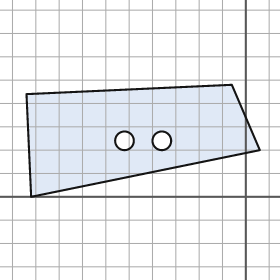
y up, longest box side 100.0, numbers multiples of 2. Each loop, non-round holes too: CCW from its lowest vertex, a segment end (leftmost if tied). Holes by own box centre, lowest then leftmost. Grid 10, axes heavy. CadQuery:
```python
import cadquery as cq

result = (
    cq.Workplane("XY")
    .moveTo(-92.0, 0.0)
    .lineTo(6.0, 20.0)
    .lineTo(-6.0, 48.0)
    .lineTo(-94.0, 44.0)
    .close()
    .moveTo(-52.0, 24.0)
    .circle(4.0)
    .moveTo(-36.0, 24.0)
    .circle(4.0)
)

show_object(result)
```